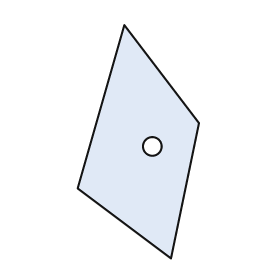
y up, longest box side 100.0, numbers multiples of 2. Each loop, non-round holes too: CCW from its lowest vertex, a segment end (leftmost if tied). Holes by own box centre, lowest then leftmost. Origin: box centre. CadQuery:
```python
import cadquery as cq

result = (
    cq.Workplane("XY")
    .moveTo(14.0, -50.0)
    .lineTo(26.0, 8.0)
    .lineTo(-6.0, 50.0)
    .lineTo(-26.0, -20.0)
    .close()
    .moveTo(6.0, -2.0)
    .circle(4.0)
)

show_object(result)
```